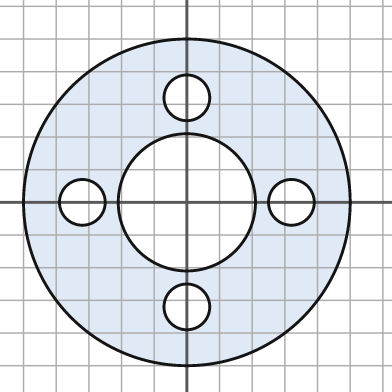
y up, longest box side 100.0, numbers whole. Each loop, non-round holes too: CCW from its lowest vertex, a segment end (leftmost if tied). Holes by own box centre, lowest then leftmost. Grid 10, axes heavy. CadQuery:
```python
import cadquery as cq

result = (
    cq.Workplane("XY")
    .moveTo(0.0, 0.0)
    .circle(50.0)
    .moveTo(0.0, -32.0)
    .circle(7.0)
    .moveTo(-32.0, 0.0)
    .circle(7.0)
    .moveTo(0.0, 0.0)
    .circle(21.0)
    .moveTo(32.0, 0.0)
    .circle(7.0)
    .moveTo(0.0, 32.0)
    .circle(7.0)
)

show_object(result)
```